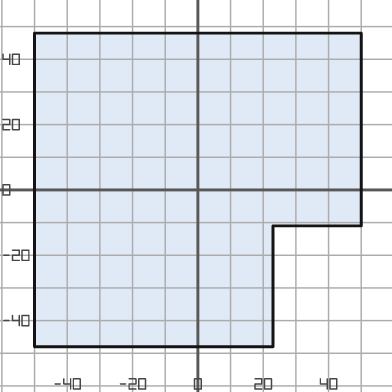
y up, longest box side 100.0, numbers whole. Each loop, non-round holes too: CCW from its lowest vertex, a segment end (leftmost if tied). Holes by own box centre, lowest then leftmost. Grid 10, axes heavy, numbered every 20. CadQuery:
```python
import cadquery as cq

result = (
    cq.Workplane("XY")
    .moveTo(-50.0, -48.0)
    .lineTo(23.0, -48.0)
    .lineTo(23.0, -11.0)
    .lineTo(50.0, -11.0)
    .lineTo(50.0, 48.0)
    .lineTo(-50.0, 48.0)
    .close()
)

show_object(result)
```